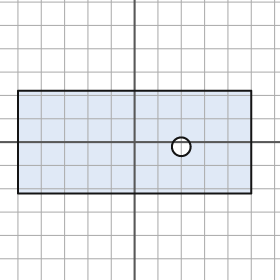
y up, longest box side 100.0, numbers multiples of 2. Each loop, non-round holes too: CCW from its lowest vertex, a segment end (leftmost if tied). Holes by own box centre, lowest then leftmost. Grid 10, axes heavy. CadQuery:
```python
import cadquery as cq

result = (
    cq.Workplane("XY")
    .moveTo(-50.0, -22.0)
    .lineTo(50.0, -22.0)
    .lineTo(50.0, 22.0)
    .lineTo(-50.0, 22.0)
    .close()
    .moveTo(20.0, -2.0)
    .circle(4.0)
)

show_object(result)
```